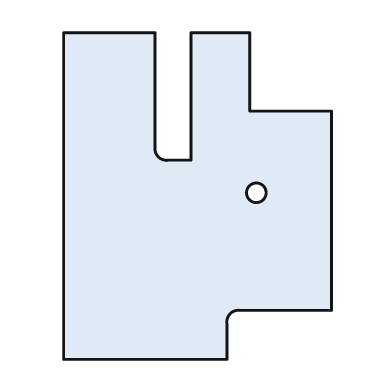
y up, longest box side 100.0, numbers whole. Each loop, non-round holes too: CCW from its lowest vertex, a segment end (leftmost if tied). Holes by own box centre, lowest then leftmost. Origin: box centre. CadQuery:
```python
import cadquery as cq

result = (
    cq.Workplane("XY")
    .moveTo(-41.0, -50.0)
    .lineTo(9.0, -50.0)
    .lineTo(9.0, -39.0)
    .threePointArc((10.0, -36.0), (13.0, -35.0))
    .lineTo(41.0, -35.0)
    .lineTo(41.0, 26.0)
    .lineTo(16.0, 26.0)
    .lineTo(16.0, 50.0)
    .lineTo(-2.0, 50.0)
    .lineTo(-2.0, 11.0)
    .lineTo(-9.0, 11.0)
    .threePointArc((-12.0, 12.0), (-13.0, 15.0))
    .lineTo(-13.0, 50.0)
    .lineTo(-41.0, 50.0)
    .close()
    .moveTo(18.0, 1.0)
    .circle(3.0)
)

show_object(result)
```